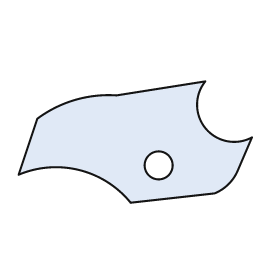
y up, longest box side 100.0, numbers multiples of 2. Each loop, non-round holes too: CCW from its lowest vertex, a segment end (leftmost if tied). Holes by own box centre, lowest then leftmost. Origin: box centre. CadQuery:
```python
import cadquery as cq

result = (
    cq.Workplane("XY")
    .moveTo(-2.0, -26.0)
    .lineTo(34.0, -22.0)
    .threePointArc((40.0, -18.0), (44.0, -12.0))
    .lineTo(50.0, 2.0)
    .threePointArc((30.0, 6.0), (30.0, 26.0))
    .lineTo(-8.0, 20.0)
    .threePointArc((-26.0, 18.0), (-42.0, 10.0))
    .lineTo(-50.0, -14.0)
    .threePointArc((-24.0, -12.0), (-2.0, -26.0))
    .close()
    .moveTo(10.0, -10.0)
    .circle(6.0)
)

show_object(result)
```